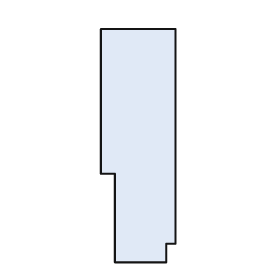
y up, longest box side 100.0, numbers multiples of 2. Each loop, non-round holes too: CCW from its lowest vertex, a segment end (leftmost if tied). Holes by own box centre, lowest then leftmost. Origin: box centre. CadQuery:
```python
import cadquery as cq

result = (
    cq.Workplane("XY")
    .moveTo(-10.0, -50.0)
    .lineTo(12.0, -50.0)
    .lineTo(12.0, -42.0)
    .lineTo(16.0, -42.0)
    .lineTo(16.0, 50.0)
    .lineTo(-16.0, 50.0)
    .lineTo(-16.0, -12.0)
    .lineTo(-10.0, -12.0)
    .close()
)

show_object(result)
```